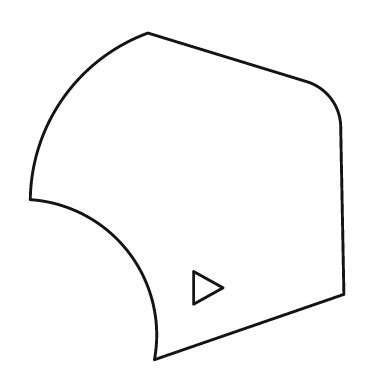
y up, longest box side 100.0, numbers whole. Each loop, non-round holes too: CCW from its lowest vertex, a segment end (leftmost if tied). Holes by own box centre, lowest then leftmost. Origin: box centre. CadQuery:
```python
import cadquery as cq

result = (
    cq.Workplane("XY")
    .moveTo(-10.0, -50.0)
    .lineTo(48.0, -30.0)
    .lineTo(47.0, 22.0)
    .threePointArc((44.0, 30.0), (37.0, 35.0))
    .lineTo(-12.0, 50.0)
    .threePointArc((-38.0, 30.0), (-48.0, -1.0))
    .threePointArc((-18.0, -17.0), (-10.0, -50.0))
    .close()
    .moveTo(2.0, -33.0)
    .lineTo(11.0, -28.0)
    .lineTo(2.0, -23.0)
    .close()
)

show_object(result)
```